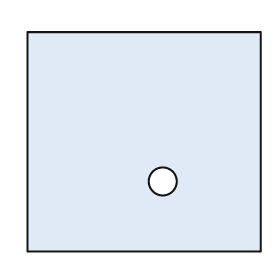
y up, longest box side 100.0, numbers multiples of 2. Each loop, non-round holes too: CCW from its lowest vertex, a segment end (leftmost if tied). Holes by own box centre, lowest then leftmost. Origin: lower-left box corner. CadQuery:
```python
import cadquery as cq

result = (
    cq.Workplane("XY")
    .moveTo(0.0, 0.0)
    .lineTo(100.0, 0.0)
    .lineTo(100.0, 94.0)
    .lineTo(0.0, 94.0)
    .close()
    .moveTo(58.0, 30.0)
    .circle(6.0)
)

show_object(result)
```